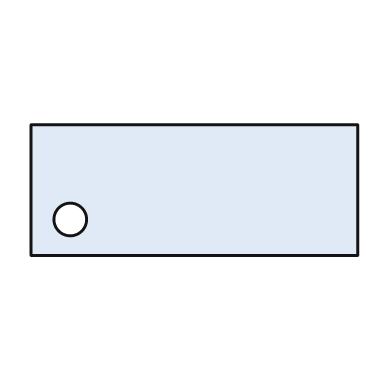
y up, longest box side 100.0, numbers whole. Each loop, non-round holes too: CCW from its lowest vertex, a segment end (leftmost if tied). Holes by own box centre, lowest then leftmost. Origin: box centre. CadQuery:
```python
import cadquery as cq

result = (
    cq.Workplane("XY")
    .moveTo(-50.0, -20.0)
    .lineTo(50.0, -20.0)
    .lineTo(50.0, 20.0)
    .lineTo(-50.0, 20.0)
    .close()
    .moveTo(-38.0, -9.0)
    .circle(5.0)
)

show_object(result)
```